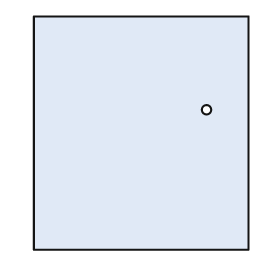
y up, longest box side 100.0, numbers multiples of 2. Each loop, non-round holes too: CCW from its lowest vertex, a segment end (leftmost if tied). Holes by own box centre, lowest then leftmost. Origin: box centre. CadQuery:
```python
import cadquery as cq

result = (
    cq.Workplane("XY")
    .moveTo(-46.0, -50.0)
    .lineTo(46.0, -50.0)
    .lineTo(46.0, 50.0)
    .lineTo(-46.0, 50.0)
    .close()
    .moveTo(28.0, 10.0)
    .circle(2.0)
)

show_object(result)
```